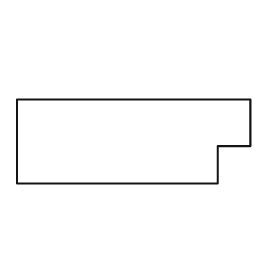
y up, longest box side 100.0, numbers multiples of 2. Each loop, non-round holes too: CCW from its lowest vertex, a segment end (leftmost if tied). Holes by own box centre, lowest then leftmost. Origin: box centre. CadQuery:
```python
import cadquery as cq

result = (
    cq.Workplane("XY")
    .moveTo(-50.0, -18.0)
    .lineTo(36.0, -18.0)
    .lineTo(36.0, -2.0)
    .lineTo(50.0, -2.0)
    .lineTo(50.0, 18.0)
    .lineTo(-50.0, 18.0)
    .close()
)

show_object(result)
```